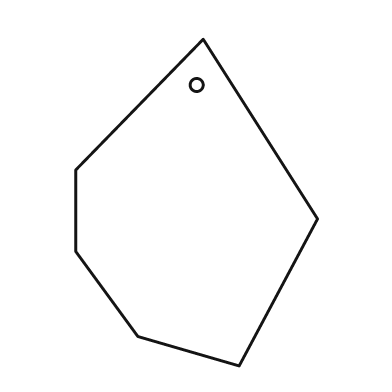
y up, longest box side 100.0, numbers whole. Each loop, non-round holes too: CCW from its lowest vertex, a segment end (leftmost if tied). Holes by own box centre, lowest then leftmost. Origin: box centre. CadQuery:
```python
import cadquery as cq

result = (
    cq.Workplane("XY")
    .moveTo(13.0, -50.0)
    .lineTo(37.0, -5.0)
    .lineTo(2.0, 50.0)
    .lineTo(-37.0, 10.0)
    .lineTo(-37.0, -15.0)
    .lineTo(-18.0, -41.0)
    .close()
    .moveTo(0.0, 36.0)
    .circle(2.0)
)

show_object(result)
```